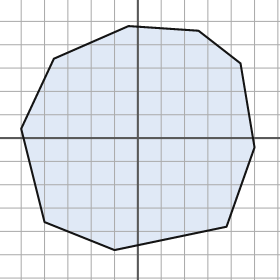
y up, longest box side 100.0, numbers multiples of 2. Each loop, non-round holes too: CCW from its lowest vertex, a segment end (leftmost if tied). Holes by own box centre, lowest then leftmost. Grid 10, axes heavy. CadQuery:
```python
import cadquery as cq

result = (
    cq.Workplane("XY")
    .moveTo(-10.0, -48.0)
    .lineTo(38.0, -38.0)
    .lineTo(50.0, -4.0)
    .lineTo(44.0, 32.0)
    .lineTo(26.0, 46.0)
    .lineTo(-4.0, 48.0)
    .lineTo(-36.0, 34.0)
    .lineTo(-50.0, 4.0)
    .lineTo(-40.0, -36.0)
    .close()
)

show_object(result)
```